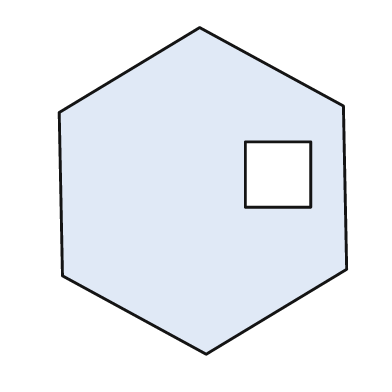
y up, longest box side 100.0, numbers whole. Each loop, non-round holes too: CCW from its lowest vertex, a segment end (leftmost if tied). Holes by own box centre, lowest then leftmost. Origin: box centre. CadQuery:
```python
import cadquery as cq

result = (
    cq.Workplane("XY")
    .moveTo(1.0, -50.0)
    .lineTo(44.0, -24.0)
    .lineTo(43.0, 26.0)
    .lineTo(-1.0, 50.0)
    .lineTo(-44.0, 24.0)
    .lineTo(-43.0, -26.0)
    .close()
    .moveTo(13.0, -5.0)
    .lineTo(33.0, -5.0)
    .lineTo(33.0, 15.0)
    .lineTo(13.0, 15.0)
    .close()
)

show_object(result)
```